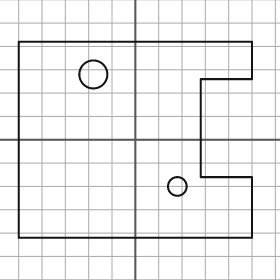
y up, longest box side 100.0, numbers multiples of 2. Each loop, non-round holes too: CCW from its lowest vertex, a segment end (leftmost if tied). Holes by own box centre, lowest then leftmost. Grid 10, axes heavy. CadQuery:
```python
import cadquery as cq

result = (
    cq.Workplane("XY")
    .moveTo(-50.0, -42.0)
    .lineTo(50.0, -42.0)
    .lineTo(50.0, -16.0)
    .lineTo(28.0, -16.0)
    .lineTo(28.0, 26.0)
    .lineTo(50.0, 26.0)
    .lineTo(50.0, 42.0)
    .lineTo(-50.0, 42.0)
    .close()
    .moveTo(18.0, -20.0)
    .circle(4.0)
    .moveTo(-18.0, 28.0)
    .circle(6.0)
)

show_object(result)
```